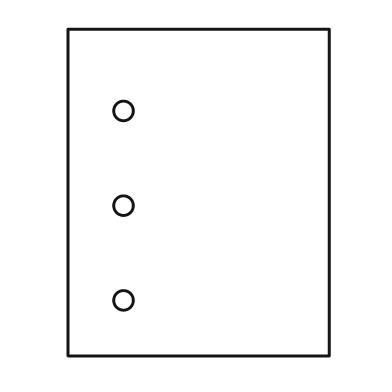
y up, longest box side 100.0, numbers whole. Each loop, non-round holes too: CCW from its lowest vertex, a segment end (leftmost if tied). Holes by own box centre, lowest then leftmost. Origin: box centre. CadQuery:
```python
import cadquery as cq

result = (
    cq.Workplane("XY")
    .moveTo(-40.0, -50.0)
    .lineTo(40.0, -50.0)
    .lineTo(40.0, 50.0)
    .lineTo(-40.0, 50.0)
    .close()
    .moveTo(-23.0, -33.0)
    .circle(3.0)
    .moveTo(-23.0, -4.0)
    .circle(3.0)
    .moveTo(-23.0, 25.0)
    .circle(3.0)
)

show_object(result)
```